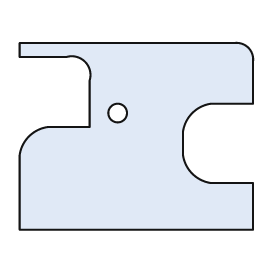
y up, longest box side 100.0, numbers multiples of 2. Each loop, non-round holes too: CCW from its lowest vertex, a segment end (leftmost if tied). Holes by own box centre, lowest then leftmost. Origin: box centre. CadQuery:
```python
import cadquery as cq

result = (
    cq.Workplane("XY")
    .moveTo(-50.0, -40.0)
    .lineTo(50.0, -40.0)
    .lineTo(50.0, -20.0)
    .lineTo(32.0, -20.0)
    .threePointArc((24.0, -16.0), (20.0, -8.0))
    .lineTo(20.0, 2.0)
    .threePointArc((24.0, 10.0), (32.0, 14.0))
    .lineTo(50.0, 14.0)
    .lineTo(50.0, 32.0)
    .threePointArc((48.0, 38.0), (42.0, 40.0))
    .lineTo(-50.0, 40.0)
    .lineTo(-50.0, 34.0)
    .lineTo(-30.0, 34.0)
    .threePointArc((-22.0, 32.0), (-20.0, 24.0))
    .lineTo(-20.0, 4.0)
    .lineTo(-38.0, 4.0)
    .threePointArc((-46.0, 0.0), (-50.0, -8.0))
    .close()
    .moveTo(-8.0, 10.0)
    .circle(4.0)
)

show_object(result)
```